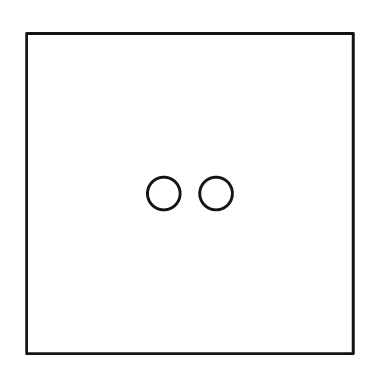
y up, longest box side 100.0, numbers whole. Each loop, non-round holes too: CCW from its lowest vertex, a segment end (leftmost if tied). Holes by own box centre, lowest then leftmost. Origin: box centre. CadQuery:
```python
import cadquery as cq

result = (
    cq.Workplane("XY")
    .moveTo(-50.0, -49.0)
    .lineTo(50.0, -49.0)
    .lineTo(50.0, 49.0)
    .lineTo(-50.0, 49.0)
    .close()
    .moveTo(-8.0, 0.0)
    .circle(5.0)
    .moveTo(8.0, 0.0)
    .circle(5.0)
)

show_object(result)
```